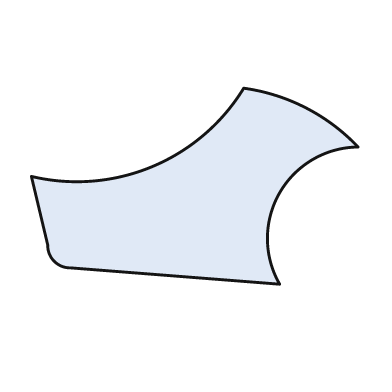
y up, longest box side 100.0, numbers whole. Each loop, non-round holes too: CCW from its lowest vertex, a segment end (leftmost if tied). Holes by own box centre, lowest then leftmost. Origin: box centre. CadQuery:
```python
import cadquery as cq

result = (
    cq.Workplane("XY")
    .moveTo(26.0, -30.0)
    .threePointArc((26.0, -2.0), (50.0, 12.0))
    .threePointArc((34.0, 24.0), (15.0, 30.0))
    .threePointArc((-13.0, 6.0), (-50.0, 3.0))
    .lineTo(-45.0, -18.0)
    .threePointArc((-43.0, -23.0), (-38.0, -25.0))
    .close()
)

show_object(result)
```